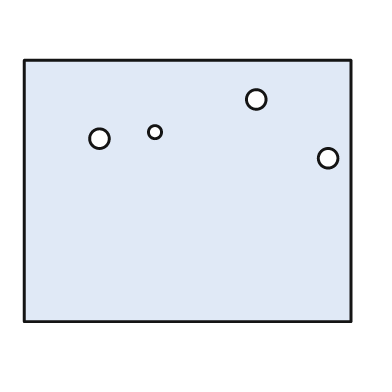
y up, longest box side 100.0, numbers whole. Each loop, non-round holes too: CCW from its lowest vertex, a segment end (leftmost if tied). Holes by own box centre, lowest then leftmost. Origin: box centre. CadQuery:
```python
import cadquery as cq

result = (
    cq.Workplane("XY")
    .moveTo(-50.0, -40.0)
    .lineTo(50.0, -40.0)
    .lineTo(50.0, 40.0)
    .lineTo(-50.0, 40.0)
    .close()
    .moveTo(43.0, 10.0)
    .circle(3.0)
    .moveTo(-27.0, 16.0)
    .circle(3.0)
    .moveTo(-10.0, 18.0)
    .circle(2.0)
    .moveTo(21.0, 28.0)
    .circle(3.0)
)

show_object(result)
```